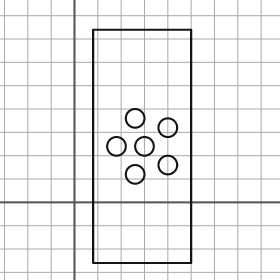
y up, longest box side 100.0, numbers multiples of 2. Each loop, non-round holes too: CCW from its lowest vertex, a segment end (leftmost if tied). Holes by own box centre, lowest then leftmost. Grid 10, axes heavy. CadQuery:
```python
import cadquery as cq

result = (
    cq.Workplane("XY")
    .moveTo(8.0, -26.0)
    .lineTo(50.0, -26.0)
    .lineTo(50.0, 74.0)
    .lineTo(8.0, 74.0)
    .close()
    .moveTo(26.0, 12.0)
    .circle(4.0)
    .moveTo(40.0, 16.0)
    .circle(4.0)
    .moveTo(18.0, 24.0)
    .circle(4.0)
    .moveTo(30.0, 24.0)
    .circle(4.0)
    .moveTo(40.0, 32.0)
    .circle(4.0)
    .moveTo(26.0, 36.0)
    .circle(4.0)
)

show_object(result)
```